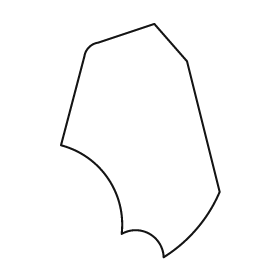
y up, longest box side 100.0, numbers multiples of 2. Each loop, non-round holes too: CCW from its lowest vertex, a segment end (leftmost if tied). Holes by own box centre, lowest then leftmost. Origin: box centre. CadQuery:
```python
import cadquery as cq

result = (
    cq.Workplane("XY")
    .moveTo(10.0, -50.0)
    .threePointArc((24.0, -38.0), (34.0, -22.0))
    .lineTo(20.0, 34.0)
    .lineTo(6.0, 50.0)
    .lineTo(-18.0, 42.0)
    .threePointArc((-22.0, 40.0), (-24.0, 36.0))
    .lineTo(-34.0, -2.0)
    .threePointArc((-14.0, -16.0), (-8.0, -40.0))
    .threePointArc((4.0, -40.0), (10.0, -50.0))
    .close()
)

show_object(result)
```